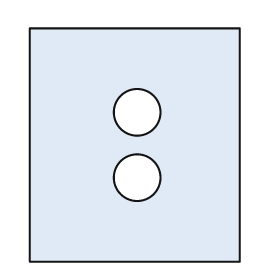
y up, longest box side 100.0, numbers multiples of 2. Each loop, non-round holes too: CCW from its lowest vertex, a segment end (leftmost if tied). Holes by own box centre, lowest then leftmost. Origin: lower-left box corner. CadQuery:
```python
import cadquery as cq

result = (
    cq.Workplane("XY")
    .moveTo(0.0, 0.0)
    .lineTo(90.0, 0.0)
    .lineTo(90.0, 100.0)
    .lineTo(0.0, 100.0)
    .close()
    .moveTo(46.0, 36.0)
    .circle(10.0)
    .moveTo(46.0, 64.0)
    .circle(10.0)
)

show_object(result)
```